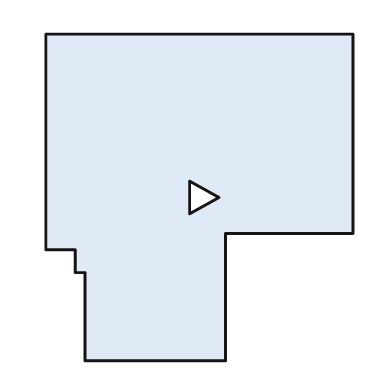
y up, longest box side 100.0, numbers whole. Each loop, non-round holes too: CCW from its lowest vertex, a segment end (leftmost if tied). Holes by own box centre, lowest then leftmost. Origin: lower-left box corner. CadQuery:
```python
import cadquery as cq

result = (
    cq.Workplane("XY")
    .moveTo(12.0, 0.0)
    .lineTo(55.0, 0.0)
    .lineTo(55.0, 39.0)
    .lineTo(94.0, 39.0)
    .lineTo(94.0, 100.0)
    .lineTo(0.0, 100.0)
    .lineTo(0.0, 34.0)
    .lineTo(9.0, 34.0)
    .lineTo(9.0, 27.0)
    .lineTo(12.0, 27.0)
    .close()
    .moveTo(44.0, 45.0)
    .lineTo(53.0, 50.0)
    .lineTo(44.0, 55.0)
    .close()
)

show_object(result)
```